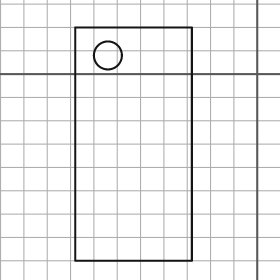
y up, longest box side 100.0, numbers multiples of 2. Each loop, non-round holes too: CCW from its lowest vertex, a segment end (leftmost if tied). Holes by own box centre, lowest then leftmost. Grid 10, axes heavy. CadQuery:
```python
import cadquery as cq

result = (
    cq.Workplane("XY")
    .moveTo(-78.0, -80.0)
    .lineTo(-28.0, -80.0)
    .lineTo(-28.0, 20.0)
    .lineTo(-78.0, 20.0)
    .close()
    .moveTo(-64.0, 8.0)
    .circle(6.0)
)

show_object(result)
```